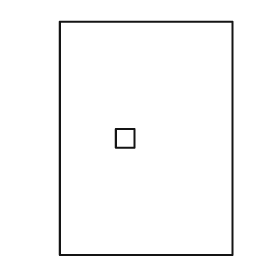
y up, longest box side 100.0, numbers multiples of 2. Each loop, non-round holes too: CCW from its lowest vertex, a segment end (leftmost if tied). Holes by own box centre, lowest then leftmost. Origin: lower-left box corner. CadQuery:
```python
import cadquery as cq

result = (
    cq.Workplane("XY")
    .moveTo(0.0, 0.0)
    .lineTo(74.0, 0.0)
    .lineTo(74.0, 100.0)
    .lineTo(0.0, 100.0)
    .close()
    .moveTo(24.0, 46.0)
    .lineTo(32.0, 46.0)
    .lineTo(32.0, 54.0)
    .lineTo(24.0, 54.0)
    .close()
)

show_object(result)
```